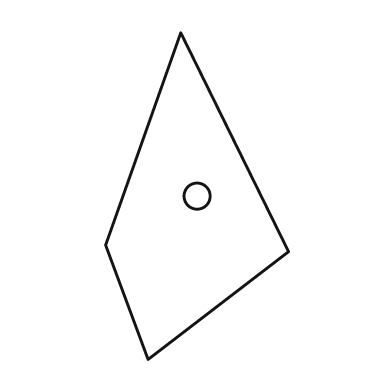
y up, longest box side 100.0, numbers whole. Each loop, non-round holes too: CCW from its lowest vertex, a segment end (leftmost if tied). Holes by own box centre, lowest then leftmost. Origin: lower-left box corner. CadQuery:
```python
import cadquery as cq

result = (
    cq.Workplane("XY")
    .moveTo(13.0, 0.0)
    .lineTo(56.0, 33.0)
    .lineTo(23.0, 100.0)
    .lineTo(0.0, 35.0)
    .close()
    .moveTo(28.0, 50.0)
    .circle(4.0)
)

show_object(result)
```